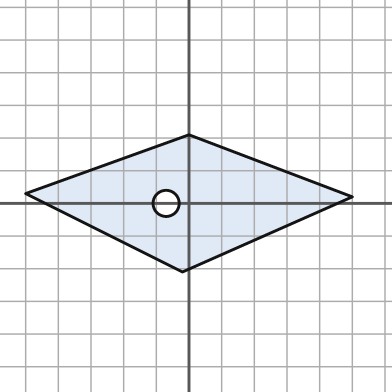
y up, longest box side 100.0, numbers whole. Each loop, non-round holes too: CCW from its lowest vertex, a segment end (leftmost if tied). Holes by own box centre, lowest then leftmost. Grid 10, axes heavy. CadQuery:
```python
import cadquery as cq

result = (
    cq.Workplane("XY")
    .moveTo(-2.0, -21.0)
    .lineTo(50.0, 2.0)
    .lineTo(0.0, 21.0)
    .lineTo(-50.0, 3.0)
    .close()
    .moveTo(-7.0, 0.0)
    .circle(4.0)
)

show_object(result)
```